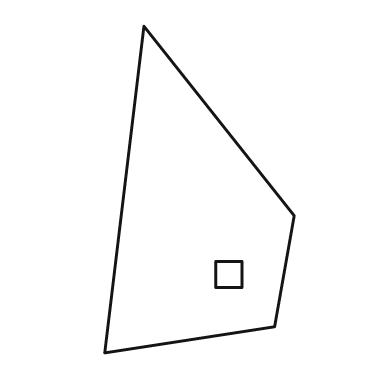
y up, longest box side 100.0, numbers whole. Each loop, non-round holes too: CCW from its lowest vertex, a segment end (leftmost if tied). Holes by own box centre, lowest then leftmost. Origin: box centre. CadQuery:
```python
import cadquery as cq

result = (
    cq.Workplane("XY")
    .moveTo(-29.0, -50.0)
    .lineTo(23.0, -42.0)
    .lineTo(29.0, -8.0)
    .lineTo(-17.0, 50.0)
    .close()
    .moveTo(5.0, -30.0)
    .lineTo(13.0, -30.0)
    .lineTo(13.0, -22.0)
    .lineTo(5.0, -22.0)
    .close()
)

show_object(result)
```